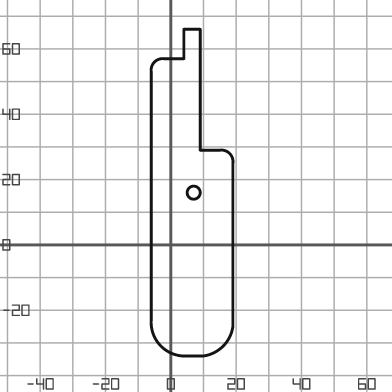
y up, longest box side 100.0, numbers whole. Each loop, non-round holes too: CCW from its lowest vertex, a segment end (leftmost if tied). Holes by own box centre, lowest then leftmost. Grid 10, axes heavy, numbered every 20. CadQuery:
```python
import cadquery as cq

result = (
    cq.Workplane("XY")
    .moveTo(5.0, -34.0)
    .lineTo(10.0, -34.0)
    .threePointArc((16.0, -31.0), (19.0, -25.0))
    .lineTo(19.0, 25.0)
    .threePointArc((18.0, 28.0), (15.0, 29.0))
    .lineTo(9.0, 29.0)
    .lineTo(9.0, 66.0)
    .lineTo(4.0, 66.0)
    .lineTo(4.0, 57.0)
    .lineTo(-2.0, 57.0)
    .threePointArc((-5.0, 56.0), (-6.0, 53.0))
    .lineTo(-6.0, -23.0)
    .threePointArc((-3.0, -31.0), (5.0, -34.0))
    .close()
    .moveTo(7.0, 16.0)
    .circle(2.0)
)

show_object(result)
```